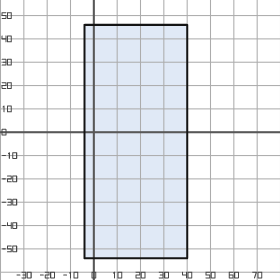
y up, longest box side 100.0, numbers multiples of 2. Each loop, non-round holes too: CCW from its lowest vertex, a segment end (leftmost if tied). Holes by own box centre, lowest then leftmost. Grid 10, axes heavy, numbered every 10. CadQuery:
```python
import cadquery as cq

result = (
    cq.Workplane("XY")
    .moveTo(-4.0, -54.0)
    .lineTo(40.0, -54.0)
    .lineTo(40.0, 46.0)
    .lineTo(-4.0, 46.0)
    .close()
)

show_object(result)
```